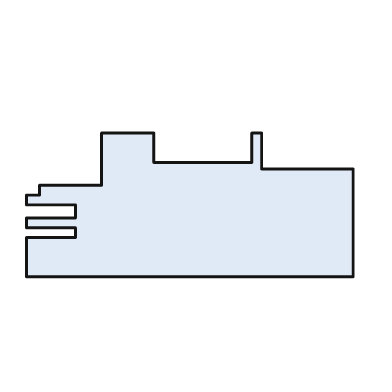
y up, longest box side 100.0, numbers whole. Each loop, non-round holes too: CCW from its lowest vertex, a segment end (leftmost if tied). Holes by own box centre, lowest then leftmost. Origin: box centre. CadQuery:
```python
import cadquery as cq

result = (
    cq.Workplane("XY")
    .moveTo(-50.0, -22.0)
    .lineTo(50.0, -22.0)
    .lineTo(50.0, 11.0)
    .lineTo(22.0, 11.0)
    .lineTo(22.0, 22.0)
    .lineTo(19.0, 22.0)
    .lineTo(19.0, 13.0)
    .lineTo(-11.0, 13.0)
    .lineTo(-11.0, 22.0)
    .lineTo(-27.0, 22.0)
    .lineTo(-27.0, 6.0)
    .lineTo(-46.0, 6.0)
    .lineTo(-46.0, 3.0)
    .lineTo(-50.0, 3.0)
    .lineTo(-50.0, 0.0)
    .lineTo(-35.0, 0.0)
    .lineTo(-35.0, -4.0)
    .lineTo(-50.0, -4.0)
    .lineTo(-50.0, -7.0)
    .lineTo(-35.0, -7.0)
    .lineTo(-35.0, -10.0)
    .lineTo(-50.0, -10.0)
    .close()
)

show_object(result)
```